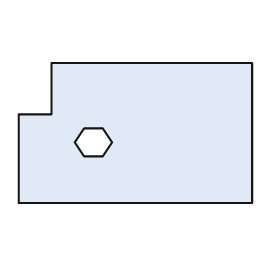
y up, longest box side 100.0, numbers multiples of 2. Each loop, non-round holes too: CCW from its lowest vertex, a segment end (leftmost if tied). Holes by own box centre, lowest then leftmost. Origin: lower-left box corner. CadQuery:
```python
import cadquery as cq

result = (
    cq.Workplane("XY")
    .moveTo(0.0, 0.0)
    .lineTo(100.0, 0.0)
    .lineTo(100.0, 60.0)
    .lineTo(14.0, 60.0)
    .lineTo(14.0, 38.0)
    .lineTo(0.0, 38.0)
    .close()
    .moveTo(28.0, 20.0)
    .lineTo(36.0, 20.0)
    .lineTo(40.0, 26.0)
    .lineTo(36.0, 32.0)
    .lineTo(28.0, 32.0)
    .lineTo(24.0, 26.0)
    .close()
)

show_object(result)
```